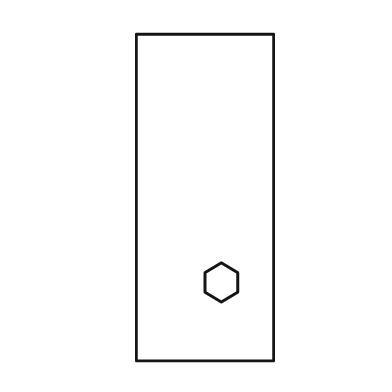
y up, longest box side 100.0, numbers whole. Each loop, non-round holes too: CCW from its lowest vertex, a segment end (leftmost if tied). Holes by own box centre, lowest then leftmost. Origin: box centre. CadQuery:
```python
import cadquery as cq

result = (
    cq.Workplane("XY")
    .moveTo(-21.0, -50.0)
    .lineTo(21.0, -50.0)
    .lineTo(21.0, 50.0)
    .lineTo(-21.0, 50.0)
    .close()
    .moveTo(5.0, -32.0)
    .lineTo(10.0, -29.0)
    .lineTo(10.0, -23.0)
    .lineTo(5.0, -20.0)
    .lineTo(0.0, -23.0)
    .lineTo(0.0, -29.0)
    .close()
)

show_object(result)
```